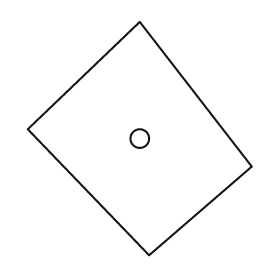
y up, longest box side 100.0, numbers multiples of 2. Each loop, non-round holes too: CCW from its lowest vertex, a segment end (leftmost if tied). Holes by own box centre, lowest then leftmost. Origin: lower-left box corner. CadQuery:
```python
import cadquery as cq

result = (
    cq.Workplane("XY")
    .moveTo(52.0, 0.0)
    .lineTo(96.0, 38.0)
    .lineTo(48.0, 100.0)
    .lineTo(0.0, 54.0)
    .close()
    .moveTo(48.0, 50.0)
    .circle(4.0)
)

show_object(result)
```